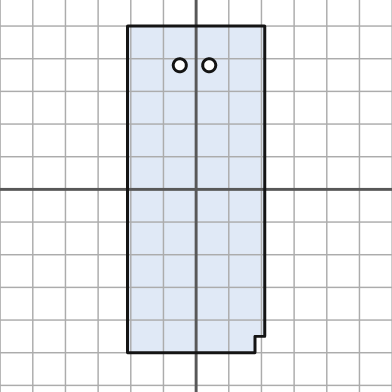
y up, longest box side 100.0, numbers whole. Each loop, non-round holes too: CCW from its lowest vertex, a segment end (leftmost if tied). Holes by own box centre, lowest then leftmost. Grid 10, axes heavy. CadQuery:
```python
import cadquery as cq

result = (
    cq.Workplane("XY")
    .moveTo(-21.0, -50.0)
    .lineTo(18.0, -50.0)
    .lineTo(18.0, -45.0)
    .lineTo(21.0, -45.0)
    .lineTo(21.0, 50.0)
    .lineTo(-21.0, 50.0)
    .close()
    .moveTo(-5.0, 38.0)
    .circle(2.0)
    .moveTo(4.0, 38.0)
    .circle(2.0)
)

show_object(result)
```